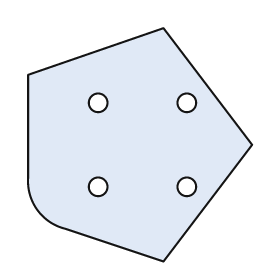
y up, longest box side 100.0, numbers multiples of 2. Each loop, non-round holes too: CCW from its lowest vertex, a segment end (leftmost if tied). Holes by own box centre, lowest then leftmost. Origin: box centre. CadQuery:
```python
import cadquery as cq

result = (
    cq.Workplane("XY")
    .moveTo(10.0, -50.0)
    .lineTo(48.0, 0.0)
    .lineTo(10.0, 50.0)
    .lineTo(-48.0, 30.0)
    .lineTo(-48.0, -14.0)
    .threePointArc((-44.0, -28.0), (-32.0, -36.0))
    .close()
    .moveTo(-18.0, -18.0)
    .circle(4.0)
    .moveTo(20.0, -18.0)
    .circle(4.0)
    .moveTo(-18.0, 18.0)
    .circle(4.0)
    .moveTo(20.0, 18.0)
    .circle(4.0)
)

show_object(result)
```